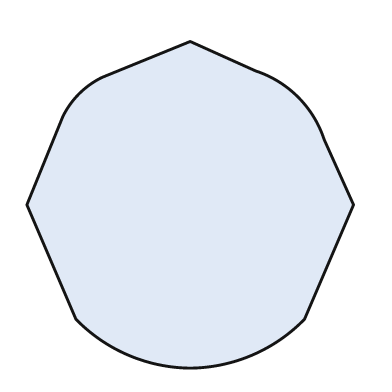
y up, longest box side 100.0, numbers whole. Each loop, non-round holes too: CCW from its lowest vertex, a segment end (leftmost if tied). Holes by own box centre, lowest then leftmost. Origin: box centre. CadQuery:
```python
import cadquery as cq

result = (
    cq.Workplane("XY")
    .moveTo(0.0, -50.0)
    .threePointArc((19.0, -46.0), (35.0, -35.0))
    .lineTo(50.0, 0.0)
    .lineTo(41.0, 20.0)
    .threePointArc((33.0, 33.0), (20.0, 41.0))
    .lineTo(0.0, 50.0)
    .lineTo(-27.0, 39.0)
    .threePointArc((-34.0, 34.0), (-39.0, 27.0))
    .lineTo(-50.0, 0.0)
    .lineTo(-35.0, -35.0)
    .threePointArc((-19.0, -46.0), (0.0, -50.0))
    .close()
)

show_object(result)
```